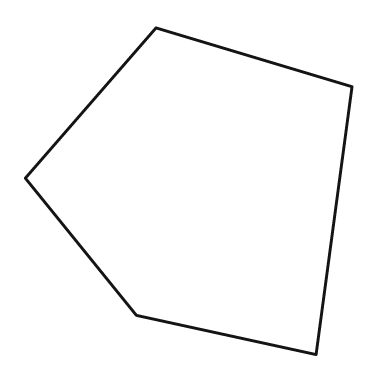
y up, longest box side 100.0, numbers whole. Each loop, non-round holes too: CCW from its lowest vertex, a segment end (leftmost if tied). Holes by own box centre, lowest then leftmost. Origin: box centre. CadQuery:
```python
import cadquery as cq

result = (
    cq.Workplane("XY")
    .moveTo(39.0, -50.0)
    .lineTo(50.0, 32.0)
    .lineTo(-10.0, 50.0)
    .lineTo(-50.0, 4.0)
    .lineTo(-16.0, -38.0)
    .close()
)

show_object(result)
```